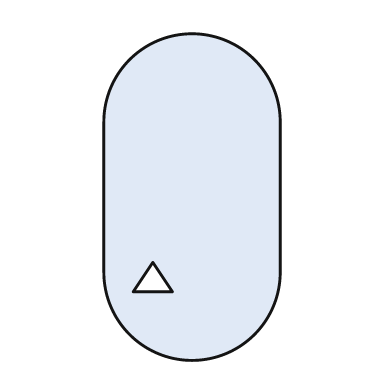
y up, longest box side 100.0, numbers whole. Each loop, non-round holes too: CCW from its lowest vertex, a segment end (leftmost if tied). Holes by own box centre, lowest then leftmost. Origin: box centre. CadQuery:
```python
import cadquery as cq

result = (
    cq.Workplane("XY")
    .moveTo(-27.0, -23.0)
    .threePointArc((0.0, -50.0), (27.0, -23.0))
    .lineTo(27.0, 23.0)
    .threePointArc((0.0, 50.0), (-27.0, 23.0))
    .close()
    .moveTo(-18.0, -29.0)
    .lineTo(-6.0, -29.0)
    .lineTo(-12.0, -20.0)
    .close()
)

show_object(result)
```